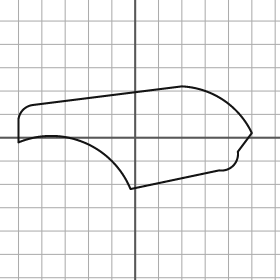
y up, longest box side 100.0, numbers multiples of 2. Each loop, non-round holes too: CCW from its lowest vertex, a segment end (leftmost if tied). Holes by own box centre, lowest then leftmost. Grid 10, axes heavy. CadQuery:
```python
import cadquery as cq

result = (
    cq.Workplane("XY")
    .moveTo(-2.0, -22.0)
    .lineTo(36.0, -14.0)
    .threePointArc((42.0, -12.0), (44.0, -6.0))
    .lineTo(50.0, 2.0)
    .threePointArc((38.0, 16.0), (20.0, 22.0))
    .lineTo(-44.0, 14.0)
    .threePointArc((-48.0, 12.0), (-50.0, 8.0))
    .lineTo(-50.0, -2.0)
    .threePointArc((-22.0, -2.0), (-2.0, -22.0))
    .close()
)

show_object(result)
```